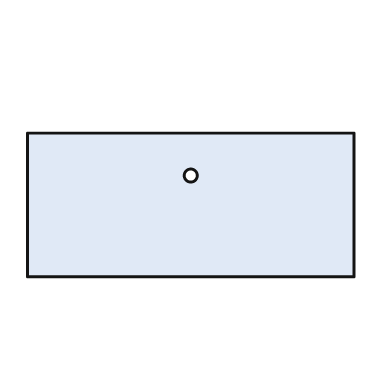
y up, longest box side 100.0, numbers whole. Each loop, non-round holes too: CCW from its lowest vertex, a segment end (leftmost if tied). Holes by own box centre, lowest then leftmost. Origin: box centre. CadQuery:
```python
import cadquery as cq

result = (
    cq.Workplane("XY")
    .moveTo(-50.0, -22.0)
    .lineTo(50.0, -22.0)
    .lineTo(50.0, 22.0)
    .lineTo(-50.0, 22.0)
    .close()
    .moveTo(0.0, 9.0)
    .circle(2.0)
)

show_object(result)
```